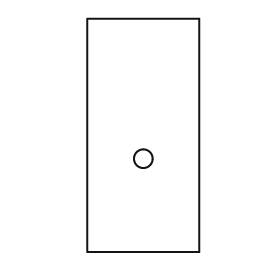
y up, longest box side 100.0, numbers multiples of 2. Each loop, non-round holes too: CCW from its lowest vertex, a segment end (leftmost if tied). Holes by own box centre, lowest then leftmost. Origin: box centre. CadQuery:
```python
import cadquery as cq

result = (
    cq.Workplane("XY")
    .moveTo(-24.0, -50.0)
    .lineTo(24.0, -50.0)
    .lineTo(24.0, 50.0)
    .lineTo(-24.0, 50.0)
    .close()
    .moveTo(0.0, -10.0)
    .circle(4.0)
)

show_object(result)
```